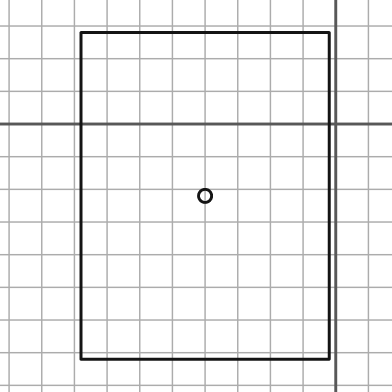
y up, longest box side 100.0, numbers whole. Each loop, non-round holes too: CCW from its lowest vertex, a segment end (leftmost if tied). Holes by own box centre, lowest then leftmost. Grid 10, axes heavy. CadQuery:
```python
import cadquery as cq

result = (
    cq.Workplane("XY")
    .moveTo(-78.0, -72.0)
    .lineTo(-2.0, -72.0)
    .lineTo(-2.0, 28.0)
    .lineTo(-78.0, 28.0)
    .close()
    .moveTo(-40.0, -22.0)
    .circle(2.0)
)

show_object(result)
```